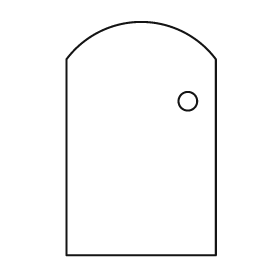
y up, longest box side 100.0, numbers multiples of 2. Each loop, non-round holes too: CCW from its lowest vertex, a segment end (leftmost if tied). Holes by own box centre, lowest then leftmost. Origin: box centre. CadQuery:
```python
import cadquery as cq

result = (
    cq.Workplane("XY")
    .moveTo(-32.0, -50.0)
    .lineTo(32.0, -50.0)
    .lineTo(32.0, 34.0)
    .threePointArc((0.0, 50.0), (-32.0, 34.0))
    .close()
    .moveTo(20.0, 16.0)
    .circle(4.0)
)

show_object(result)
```